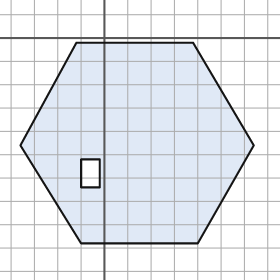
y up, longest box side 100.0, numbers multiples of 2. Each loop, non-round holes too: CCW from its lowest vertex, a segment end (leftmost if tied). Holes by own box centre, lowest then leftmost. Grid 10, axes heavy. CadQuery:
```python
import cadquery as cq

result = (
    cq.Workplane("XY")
    .moveTo(-10.0, -88.0)
    .lineTo(40.0, -88.0)
    .lineTo(64.0, -46.0)
    .lineTo(38.0, -2.0)
    .lineTo(-12.0, -2.0)
    .lineTo(-36.0, -46.0)
    .close()
    .moveTo(-10.0, -64.0)
    .lineTo(-2.0, -64.0)
    .lineTo(-2.0, -52.0)
    .lineTo(-10.0, -52.0)
    .close()
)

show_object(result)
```